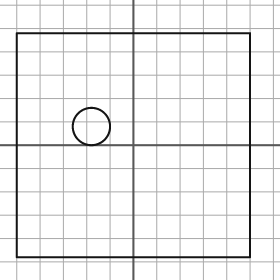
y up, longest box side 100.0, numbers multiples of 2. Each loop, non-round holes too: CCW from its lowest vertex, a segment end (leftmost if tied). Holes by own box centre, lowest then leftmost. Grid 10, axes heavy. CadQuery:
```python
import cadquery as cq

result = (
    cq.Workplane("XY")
    .moveTo(-50.0, -48.0)
    .lineTo(50.0, -48.0)
    .lineTo(50.0, 48.0)
    .lineTo(-50.0, 48.0)
    .close()
    .moveTo(-18.0, 8.0)
    .circle(8.0)
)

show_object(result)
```